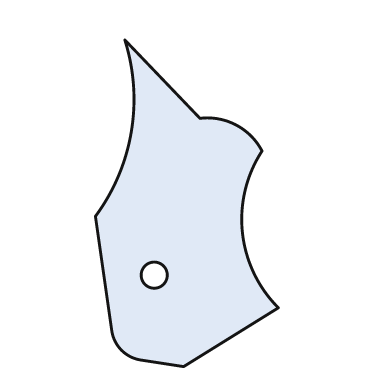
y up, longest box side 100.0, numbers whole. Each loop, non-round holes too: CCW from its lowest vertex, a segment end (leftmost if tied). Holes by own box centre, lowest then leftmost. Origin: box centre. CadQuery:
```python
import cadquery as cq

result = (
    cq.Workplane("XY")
    .moveTo(-1.0, -50.0)
    .lineTo(28.0, -32.0)
    .threePointArc((17.0, -9.0), (23.0, 16.0))
    .threePointArc((15.0, 24.0), (4.0, 26.0))
    .lineTo(-19.0, 50.0)
    .threePointArc((-17.0, 22.0), (-28.0, -4.0))
    .lineTo(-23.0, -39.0)
    .threePointArc((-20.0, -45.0), (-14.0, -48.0))
    .close()
    .moveTo(-10.0, -22.0)
    .circle(4.0)
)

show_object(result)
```